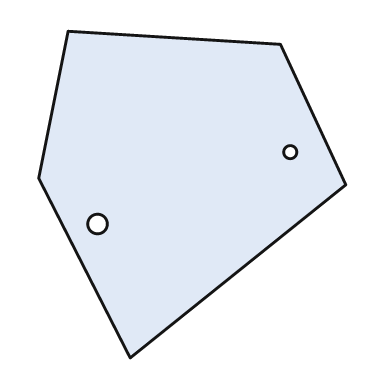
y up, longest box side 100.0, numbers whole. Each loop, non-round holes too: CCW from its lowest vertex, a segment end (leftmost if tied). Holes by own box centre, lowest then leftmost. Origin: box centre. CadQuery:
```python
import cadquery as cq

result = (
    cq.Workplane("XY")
    .moveTo(-19.0, -50.0)
    .lineTo(47.0, 3.0)
    .lineTo(27.0, 46.0)
    .lineTo(-38.0, 50.0)
    .lineTo(-47.0, 5.0)
    .close()
    .moveTo(-29.0, -9.0)
    .circle(3.0)
    .moveTo(30.0, 13.0)
    .circle(2.0)
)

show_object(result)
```